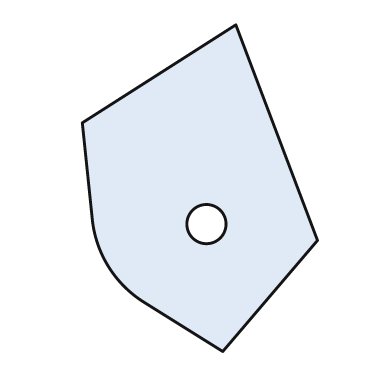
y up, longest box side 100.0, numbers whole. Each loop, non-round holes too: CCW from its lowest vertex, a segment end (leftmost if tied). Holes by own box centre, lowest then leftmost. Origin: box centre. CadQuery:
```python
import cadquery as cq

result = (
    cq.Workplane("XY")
    .moveTo(7.0, -50.0)
    .lineTo(36.0, -16.0)
    .lineTo(11.0, 50.0)
    .lineTo(-36.0, 20.0)
    .lineTo(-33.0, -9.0)
    .threePointArc((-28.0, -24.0), (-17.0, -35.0))
    .close()
    .moveTo(2.0, -11.0)
    .circle(6.0)
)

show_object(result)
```